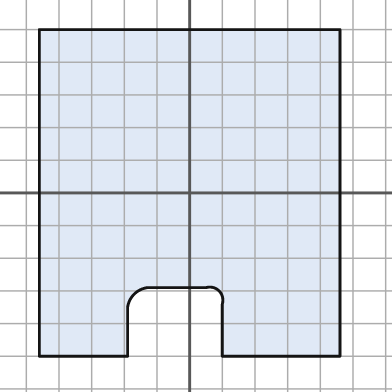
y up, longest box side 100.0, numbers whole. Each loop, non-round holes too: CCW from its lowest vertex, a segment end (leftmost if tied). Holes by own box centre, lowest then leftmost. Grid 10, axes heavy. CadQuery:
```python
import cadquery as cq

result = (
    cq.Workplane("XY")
    .moveTo(-46.0, -50.0)
    .lineTo(-19.0, -50.0)
    .lineTo(-19.0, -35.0)
    .threePointArc((-17.0, -31.0), (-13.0, -29.0))
    .lineTo(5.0, -29.0)
    .threePointArc((9.0, -30.0), (10.0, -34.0))
    .lineTo(10.0, -50.0)
    .lineTo(46.0, -50.0)
    .lineTo(46.0, 50.0)
    .lineTo(-46.0, 50.0)
    .close()
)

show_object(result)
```